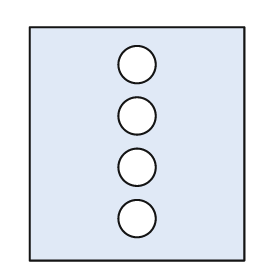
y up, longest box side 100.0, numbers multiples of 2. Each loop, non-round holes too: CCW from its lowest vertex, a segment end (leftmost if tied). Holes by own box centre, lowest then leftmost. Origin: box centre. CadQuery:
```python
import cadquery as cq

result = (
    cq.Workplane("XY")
    .moveTo(-46.0, -50.0)
    .lineTo(46.0, -50.0)
    .lineTo(46.0, 50.0)
    .lineTo(-46.0, 50.0)
    .close()
    .moveTo(0.0, -32.0)
    .circle(8.0)
    .moveTo(0.0, -10.0)
    .circle(8.0)
    .moveTo(0.0, 12.0)
    .circle(8.0)
    .moveTo(0.0, 34.0)
    .circle(8.0)
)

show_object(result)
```